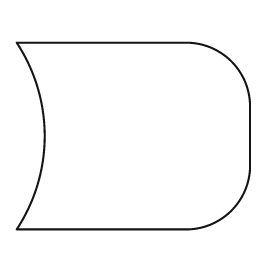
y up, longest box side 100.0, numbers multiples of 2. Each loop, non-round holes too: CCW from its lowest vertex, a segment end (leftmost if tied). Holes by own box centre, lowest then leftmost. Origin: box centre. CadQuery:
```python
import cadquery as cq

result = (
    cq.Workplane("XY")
    .moveTo(-50.0, -40.0)
    .lineTo(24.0, -40.0)
    .threePointArc((42.0, -32.0), (50.0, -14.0))
    .lineTo(50.0, 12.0)
    .threePointArc((42.0, 32.0), (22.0, 40.0))
    .lineTo(-50.0, 40.0)
    .threePointArc((-38.0, 0.0), (-50.0, -40.0))
    .close()
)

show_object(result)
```